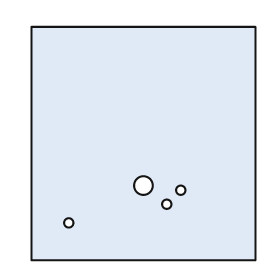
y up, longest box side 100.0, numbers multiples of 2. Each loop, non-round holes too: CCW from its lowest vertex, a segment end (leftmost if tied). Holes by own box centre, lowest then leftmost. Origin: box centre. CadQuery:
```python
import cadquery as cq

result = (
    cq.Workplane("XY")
    .moveTo(-48.0, -50.0)
    .lineTo(48.0, -50.0)
    .lineTo(48.0, 50.0)
    .lineTo(-48.0, 50.0)
    .close()
    .moveTo(-32.0, -34.0)
    .circle(2.0)
    .moveTo(10.0, -26.0)
    .circle(2.0)
    .moveTo(16.0, -20.0)
    .circle(2.0)
    .moveTo(0.0, -18.0)
    .circle(4.0)
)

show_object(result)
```